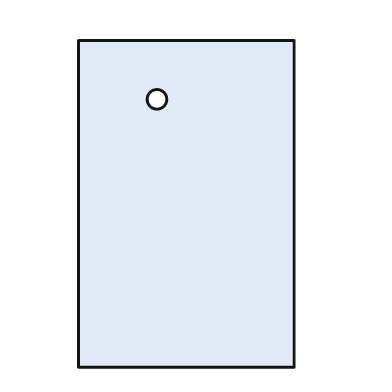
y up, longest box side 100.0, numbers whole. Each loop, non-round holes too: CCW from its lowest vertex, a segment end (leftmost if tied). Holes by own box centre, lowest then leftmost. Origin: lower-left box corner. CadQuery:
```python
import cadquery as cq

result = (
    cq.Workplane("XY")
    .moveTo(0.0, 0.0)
    .lineTo(66.0, 0.0)
    .lineTo(66.0, 100.0)
    .lineTo(0.0, 100.0)
    .close()
    .moveTo(24.0, 82.0)
    .circle(3.0)
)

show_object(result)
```